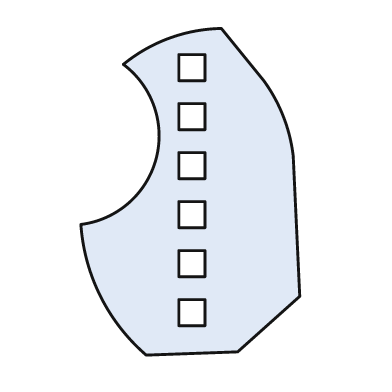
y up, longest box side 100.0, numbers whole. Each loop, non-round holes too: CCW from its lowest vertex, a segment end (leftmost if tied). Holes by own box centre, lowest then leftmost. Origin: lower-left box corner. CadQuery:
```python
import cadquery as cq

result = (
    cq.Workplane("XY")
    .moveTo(20.0, 0.0)
    .lineTo(48.0, 1.0)
    .lineTo(67.0, 18.0)
    .lineTo(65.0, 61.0)
    .threePointArc((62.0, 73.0), (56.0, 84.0))
    .lineTo(43.0, 100.0)
    .threePointArc((27.0, 97.0), (13.0, 89.0))
    .threePointArc((23.0, 60.0), (0.0, 40.0))
    .threePointArc((6.0, 18.0), (20.0, 0.0))
    .close()
    .moveTo(30.0, 9.0)
    .lineTo(38.0, 9.0)
    .lineTo(38.0, 17.0)
    .lineTo(30.0, 17.0)
    .close()
    .moveTo(30.0, 24.0)
    .lineTo(38.0, 24.0)
    .lineTo(38.0, 32.0)
    .lineTo(30.0, 32.0)
    .close()
    .moveTo(30.0, 39.0)
    .lineTo(38.0, 39.0)
    .lineTo(38.0, 47.0)
    .lineTo(30.0, 47.0)
    .close()
    .moveTo(30.0, 54.0)
    .lineTo(38.0, 54.0)
    .lineTo(38.0, 62.0)
    .lineTo(30.0, 62.0)
    .close()
    .moveTo(30.0, 69.0)
    .lineTo(38.0, 69.0)
    .lineTo(38.0, 77.0)
    .lineTo(30.0, 77.0)
    .close()
    .moveTo(30.0, 84.0)
    .lineTo(38.0, 84.0)
    .lineTo(38.0, 92.0)
    .lineTo(30.0, 92.0)
    .close()
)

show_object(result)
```